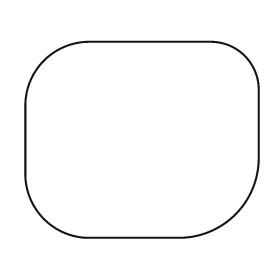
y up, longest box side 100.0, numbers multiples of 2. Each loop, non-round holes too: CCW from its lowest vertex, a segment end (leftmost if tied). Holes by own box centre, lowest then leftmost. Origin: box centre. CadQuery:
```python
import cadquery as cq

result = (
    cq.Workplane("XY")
    .moveTo(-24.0, -42.0)
    .lineTo(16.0, -42.0)
    .threePointArc((40.0, -32.0), (50.0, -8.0))
    .lineTo(50.0, 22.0)
    .threePointArc((44.0, 36.0), (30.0, 42.0))
    .lineTo(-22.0, 42.0)
    .threePointArc((-42.0, 34.0), (-50.0, 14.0))
    .lineTo(-50.0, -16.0)
    .threePointArc((-42.0, -34.0), (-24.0, -42.0))
    .close()
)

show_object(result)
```